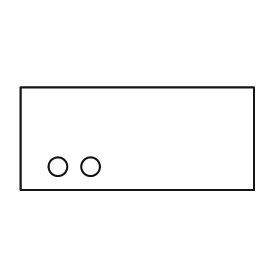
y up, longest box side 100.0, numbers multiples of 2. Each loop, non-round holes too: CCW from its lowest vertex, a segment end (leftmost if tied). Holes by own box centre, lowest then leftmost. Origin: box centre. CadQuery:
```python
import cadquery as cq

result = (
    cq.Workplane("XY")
    .moveTo(-50.0, -22.0)
    .lineTo(50.0, -22.0)
    .lineTo(50.0, 22.0)
    .lineTo(-50.0, 22.0)
    .close()
    .moveTo(-34.0, -12.0)
    .circle(4.0)
    .moveTo(-20.0, -12.0)
    .circle(4.0)
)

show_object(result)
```